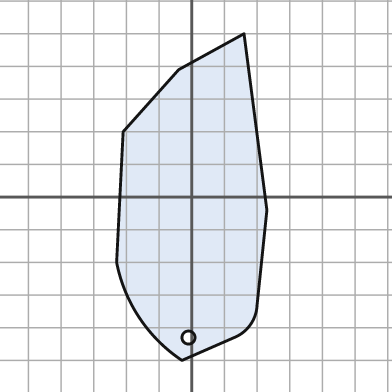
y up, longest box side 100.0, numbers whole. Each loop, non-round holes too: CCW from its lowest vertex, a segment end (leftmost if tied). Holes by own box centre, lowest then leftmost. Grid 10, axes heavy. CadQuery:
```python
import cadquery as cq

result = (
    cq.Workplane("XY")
    .moveTo(-3.0, -50.0)
    .lineTo(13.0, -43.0)
    .threePointArc((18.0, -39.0), (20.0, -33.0))
    .lineTo(23.0, -4.0)
    .lineTo(16.0, 50.0)
    .lineTo(-4.0, 39.0)
    .lineTo(-21.0, 20.0)
    .lineTo(-23.0, -20.0)
    .threePointArc((-16.0, -37.0), (-3.0, -50.0))
    .close()
    .moveTo(-1.0, -43.0)
    .circle(2.0)
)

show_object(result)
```